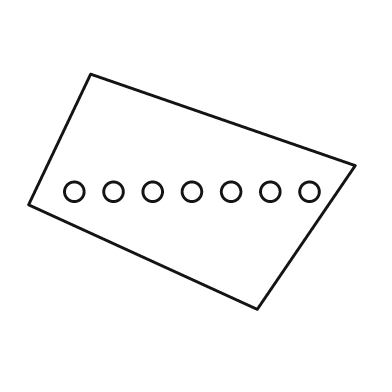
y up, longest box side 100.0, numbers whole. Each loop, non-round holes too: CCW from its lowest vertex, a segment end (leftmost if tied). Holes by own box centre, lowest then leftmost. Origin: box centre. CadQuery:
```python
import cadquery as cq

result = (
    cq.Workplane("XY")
    .moveTo(20.0, -36.0)
    .lineTo(50.0, 8.0)
    .lineTo(-31.0, 36.0)
    .lineTo(-50.0, -4.0)
    .close()
    .moveTo(-36.0, 0.0)
    .circle(3.0)
    .moveTo(-24.0, 0.0)
    .circle(3.0)
    .moveTo(-12.0, 0.0)
    .circle(3.0)
    .moveTo(0.0, 0.0)
    .circle(3.0)
    .moveTo(12.0, 0.0)
    .circle(3.0)
    .moveTo(24.0, 0.0)
    .circle(3.0)
    .moveTo(36.0, 0.0)
    .circle(3.0)
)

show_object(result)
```